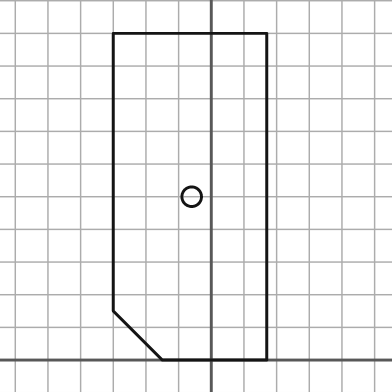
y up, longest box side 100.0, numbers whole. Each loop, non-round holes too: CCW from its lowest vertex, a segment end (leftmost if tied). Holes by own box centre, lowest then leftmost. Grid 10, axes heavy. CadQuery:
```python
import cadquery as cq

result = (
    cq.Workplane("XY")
    .moveTo(-15.0, 0.0)
    .lineTo(17.0, 0.0)
    .lineTo(17.0, 100.0)
    .lineTo(-30.0, 100.0)
    .lineTo(-30.0, 15.0)
    .close()
    .moveTo(-6.0, 50.0)
    .circle(3.0)
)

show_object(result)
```